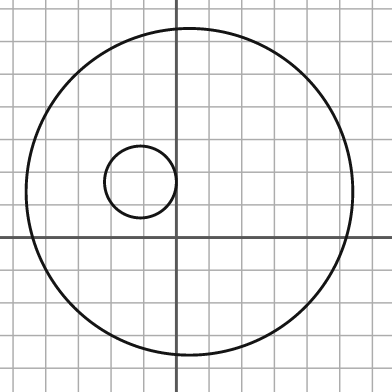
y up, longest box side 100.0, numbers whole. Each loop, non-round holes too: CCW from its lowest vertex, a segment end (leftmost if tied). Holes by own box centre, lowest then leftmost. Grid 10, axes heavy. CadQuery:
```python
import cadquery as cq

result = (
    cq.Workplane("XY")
    .moveTo(4.0, 14.0)
    .circle(50.0)
    .moveTo(-11.0, 17.0)
    .circle(11.0)
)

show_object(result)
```